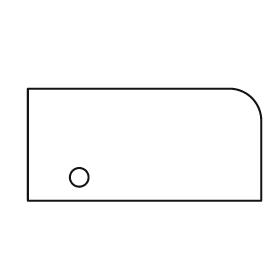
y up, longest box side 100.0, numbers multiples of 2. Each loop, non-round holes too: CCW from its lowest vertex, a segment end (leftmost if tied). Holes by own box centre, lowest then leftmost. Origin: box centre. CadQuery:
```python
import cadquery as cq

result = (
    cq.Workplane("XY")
    .moveTo(-50.0, -24.0)
    .lineTo(50.0, -24.0)
    .lineTo(50.0, 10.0)
    .threePointArc((46.0, 20.0), (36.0, 24.0))
    .lineTo(-50.0, 24.0)
    .close()
    .moveTo(-28.0, -14.0)
    .circle(4.0)
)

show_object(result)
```